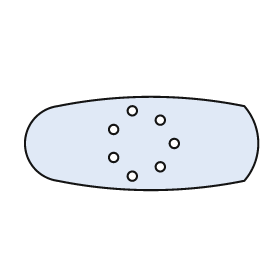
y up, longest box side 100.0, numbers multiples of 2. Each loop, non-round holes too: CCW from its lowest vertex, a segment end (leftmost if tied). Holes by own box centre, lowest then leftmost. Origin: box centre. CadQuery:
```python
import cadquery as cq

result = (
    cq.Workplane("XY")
    .moveTo(-36.0, -16.0)
    .threePointArc((4.0, -20.0), (44.0, -16.0))
    .threePointArc((50.0, 0.0), (44.0, 16.0))
    .threePointArc((4.0, 20.0), (-36.0, 16.0))
    .threePointArc((-50.0, 0.0), (-36.0, -16.0))
    .close()
    .moveTo(-4.0, -14.0)
    .circle(2.0)
    .moveTo(8.0, -10.0)
    .circle(2.0)
    .moveTo(-12.0, -6.0)
    .circle(2.0)
    .moveTo(14.0, 0.0)
    .circle(2.0)
    .moveTo(-12.0, 6.0)
    .circle(2.0)
    .moveTo(8.0, 10.0)
    .circle(2.0)
    .moveTo(-4.0, 14.0)
    .circle(2.0)
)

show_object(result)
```